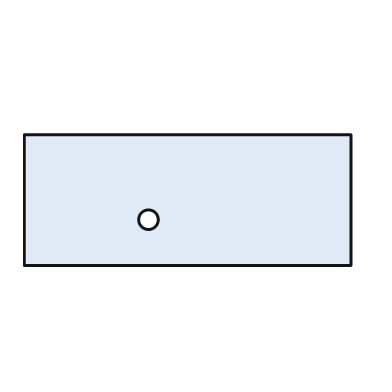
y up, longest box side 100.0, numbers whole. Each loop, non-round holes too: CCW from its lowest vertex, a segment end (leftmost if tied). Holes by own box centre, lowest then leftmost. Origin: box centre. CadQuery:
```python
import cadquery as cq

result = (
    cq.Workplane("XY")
    .moveTo(-50.0, -20.0)
    .lineTo(50.0, -20.0)
    .lineTo(50.0, 20.0)
    .lineTo(-50.0, 20.0)
    .close()
    .moveTo(-12.0, -6.0)
    .circle(3.0)
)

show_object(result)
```